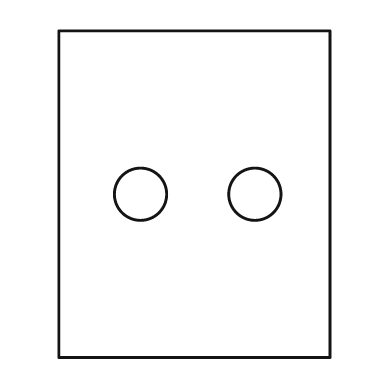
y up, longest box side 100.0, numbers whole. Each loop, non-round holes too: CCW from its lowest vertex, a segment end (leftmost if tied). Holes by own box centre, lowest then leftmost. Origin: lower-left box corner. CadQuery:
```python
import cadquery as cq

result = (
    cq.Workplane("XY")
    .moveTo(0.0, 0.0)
    .lineTo(83.0, 0.0)
    .lineTo(83.0, 100.0)
    .lineTo(0.0, 100.0)
    .close()
    .moveTo(25.0, 50.0)
    .circle(8.0)
    .moveTo(60.0, 50.0)
    .circle(8.0)
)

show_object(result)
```